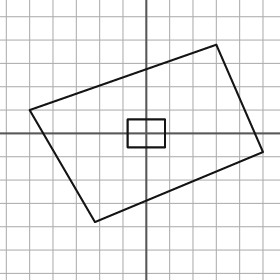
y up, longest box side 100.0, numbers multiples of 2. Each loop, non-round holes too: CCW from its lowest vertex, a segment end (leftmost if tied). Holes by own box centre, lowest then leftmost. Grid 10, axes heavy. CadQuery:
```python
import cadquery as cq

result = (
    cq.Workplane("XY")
    .moveTo(-22.0, -38.0)
    .lineTo(50.0, -8.0)
    .lineTo(30.0, 38.0)
    .lineTo(-50.0, 10.0)
    .close()
    .moveTo(-8.0, -6.0)
    .lineTo(8.0, -6.0)
    .lineTo(8.0, 6.0)
    .lineTo(-8.0, 6.0)
    .close()
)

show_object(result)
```